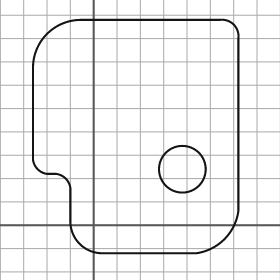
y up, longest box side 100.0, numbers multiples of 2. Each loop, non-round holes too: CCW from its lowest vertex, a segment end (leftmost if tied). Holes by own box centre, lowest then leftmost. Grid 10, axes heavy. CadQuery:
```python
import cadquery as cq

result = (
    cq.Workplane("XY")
    .moveTo(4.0, -12.0)
    .lineTo(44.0, -12.0)
    .threePointArc((56.0, -6.0), (62.0, 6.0))
    .lineTo(62.0, 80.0)
    .threePointArc((60.0, 86.0), (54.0, 88.0))
    .lineTo(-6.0, 88.0)
    .threePointArc((-20.0, 82.0), (-26.0, 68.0))
    .lineTo(-26.0, 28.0)
    .threePointArc((-24.0, 24.0), (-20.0, 22.0))
    .lineTo(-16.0, 22.0)
    .threePointArc((-12.0, 20.0), (-10.0, 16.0))
    .lineTo(-10.0, 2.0)
    .threePointArc((-6.0, -8.0), (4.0, -12.0))
    .close()
    .moveTo(38.0, 24.0)
    .circle(10.0)
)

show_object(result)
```